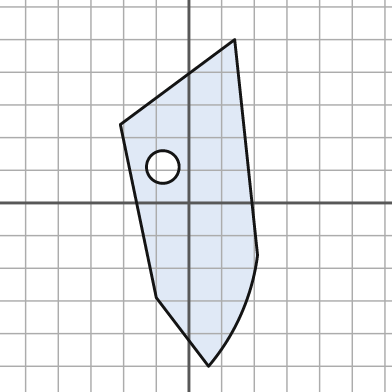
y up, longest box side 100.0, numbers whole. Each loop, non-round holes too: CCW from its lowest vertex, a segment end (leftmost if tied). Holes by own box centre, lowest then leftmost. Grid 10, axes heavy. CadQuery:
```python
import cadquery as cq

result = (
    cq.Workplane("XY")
    .moveTo(6.0, -50.0)
    .threePointArc((16.0, -34.0), (21.0, -16.0))
    .lineTo(14.0, 50.0)
    .lineTo(-21.0, 24.0)
    .lineTo(-10.0, -29.0)
    .close()
    .moveTo(-8.0, 11.0)
    .circle(5.0)
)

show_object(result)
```